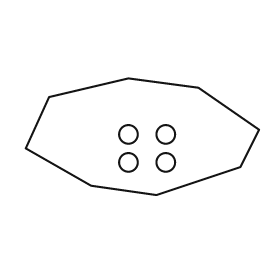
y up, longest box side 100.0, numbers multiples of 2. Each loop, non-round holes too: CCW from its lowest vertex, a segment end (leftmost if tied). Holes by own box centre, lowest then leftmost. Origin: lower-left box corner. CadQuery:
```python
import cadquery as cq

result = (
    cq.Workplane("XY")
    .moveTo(56.0, 0.0)
    .lineTo(92.0, 12.0)
    .lineTo(100.0, 28.0)
    .lineTo(74.0, 46.0)
    .lineTo(44.0, 50.0)
    .lineTo(10.0, 42.0)
    .lineTo(0.0, 20.0)
    .lineTo(28.0, 4.0)
    .close()
    .moveTo(44.0, 14.0)
    .circle(4.0)
    .moveTo(60.0, 14.0)
    .circle(4.0)
    .moveTo(44.0, 26.0)
    .circle(4.0)
    .moveTo(60.0, 26.0)
    .circle(4.0)
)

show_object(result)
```